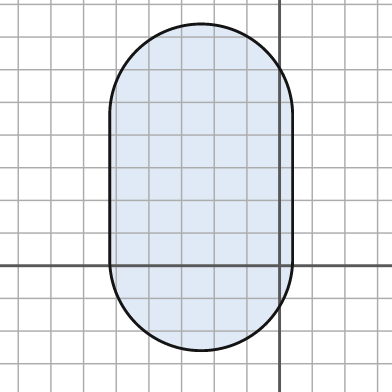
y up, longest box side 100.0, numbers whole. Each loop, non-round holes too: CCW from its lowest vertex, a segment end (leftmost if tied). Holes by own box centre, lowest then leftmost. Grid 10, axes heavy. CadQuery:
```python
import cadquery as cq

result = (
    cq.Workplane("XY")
    .moveTo(-52.0, 2.0)
    .threePointArc((-24.0, -26.0), (4.0, 2.0))
    .lineTo(4.0, 46.0)
    .threePointArc((-24.0, 74.0), (-52.0, 46.0))
    .close()
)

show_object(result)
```